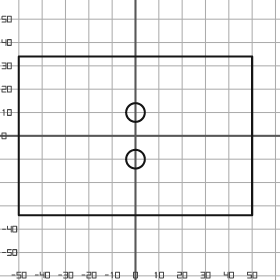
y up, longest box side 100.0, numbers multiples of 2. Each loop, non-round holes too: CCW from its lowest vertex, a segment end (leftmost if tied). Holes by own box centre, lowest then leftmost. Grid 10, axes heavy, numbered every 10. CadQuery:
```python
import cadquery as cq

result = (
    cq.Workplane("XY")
    .moveTo(-50.0, -34.0)
    .lineTo(50.0, -34.0)
    .lineTo(50.0, 34.0)
    .lineTo(-50.0, 34.0)
    .close()
    .moveTo(0.0, -10.0)
    .circle(4.0)
    .moveTo(0.0, 10.0)
    .circle(4.0)
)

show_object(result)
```